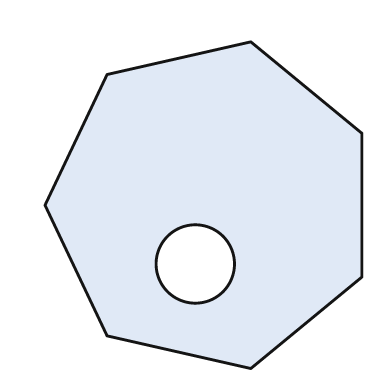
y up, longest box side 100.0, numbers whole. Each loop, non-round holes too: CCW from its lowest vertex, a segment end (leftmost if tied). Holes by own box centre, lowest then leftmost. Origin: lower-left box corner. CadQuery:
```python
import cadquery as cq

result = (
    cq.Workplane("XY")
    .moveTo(63.0, 0.0)
    .lineTo(97.0, 28.0)
    .lineTo(97.0, 72.0)
    .lineTo(63.0, 100.0)
    .lineTo(19.0, 90.0)
    .lineTo(0.0, 50.0)
    .lineTo(19.0, 10.0)
    .close()
    .moveTo(46.0, 32.0)
    .circle(12.0)
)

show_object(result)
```